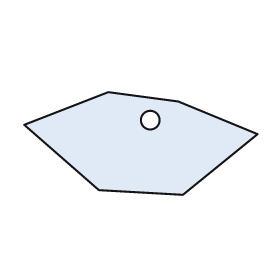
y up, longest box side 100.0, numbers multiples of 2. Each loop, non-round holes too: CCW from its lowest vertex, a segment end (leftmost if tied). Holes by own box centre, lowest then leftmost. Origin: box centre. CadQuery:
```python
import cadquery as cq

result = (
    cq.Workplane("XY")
    .moveTo(18.0, -22.0)
    .lineTo(50.0, 4.0)
    .lineTo(16.0, 18.0)
    .lineTo(-14.0, 22.0)
    .lineTo(-50.0, 8.0)
    .lineTo(-18.0, -20.0)
    .close()
    .moveTo(4.0, 10.0)
    .circle(4.0)
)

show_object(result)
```